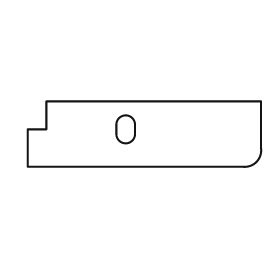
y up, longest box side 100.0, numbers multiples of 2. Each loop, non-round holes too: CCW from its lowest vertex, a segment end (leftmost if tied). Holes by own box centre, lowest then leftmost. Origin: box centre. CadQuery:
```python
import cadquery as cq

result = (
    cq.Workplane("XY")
    .moveTo(-50.0, -14.0)
    .lineTo(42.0, -14.0)
    .threePointArc((48.0, -12.0), (50.0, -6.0))
    .lineTo(50.0, 14.0)
    .lineTo(-42.0, 14.0)
    .lineTo(-42.0, 2.0)
    .lineTo(-50.0, 2.0)
    .close()
    .moveTo(-12.0, 0.0)
    .threePointArc((-8.0, -4.0), (-4.0, 0.0))
    .lineTo(-4.0, 4.0)
    .threePointArc((-8.0, 8.0), (-12.0, 4.0))
    .close()
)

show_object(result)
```